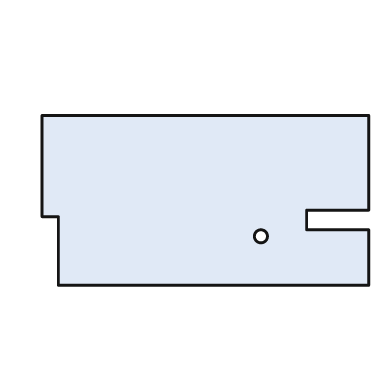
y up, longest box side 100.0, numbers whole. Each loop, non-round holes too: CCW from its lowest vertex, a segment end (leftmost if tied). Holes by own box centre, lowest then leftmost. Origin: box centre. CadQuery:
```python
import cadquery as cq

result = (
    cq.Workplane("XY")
    .moveTo(-45.0, -26.0)
    .lineTo(50.0, -26.0)
    .lineTo(50.0, -9.0)
    .lineTo(31.0, -9.0)
    .lineTo(31.0, -3.0)
    .lineTo(50.0, -3.0)
    .lineTo(50.0, 26.0)
    .lineTo(-50.0, 26.0)
    .lineTo(-50.0, -5.0)
    .lineTo(-45.0, -5.0)
    .close()
    .moveTo(17.0, -11.0)
    .circle(2.0)
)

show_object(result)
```